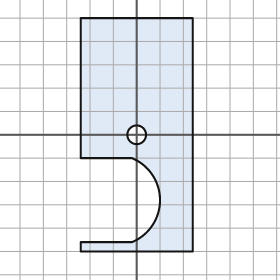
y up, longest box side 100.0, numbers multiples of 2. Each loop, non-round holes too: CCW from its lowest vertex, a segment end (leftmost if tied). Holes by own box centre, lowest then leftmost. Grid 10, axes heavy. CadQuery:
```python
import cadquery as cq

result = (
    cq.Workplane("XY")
    .moveTo(-24.0, -50.0)
    .lineTo(24.0, -50.0)
    .lineTo(24.0, 50.0)
    .lineTo(-24.0, 50.0)
    .lineTo(-24.0, -10.0)
    .lineTo(-2.0, -10.0)
    .threePointArc((10.0, -28.0), (-2.0, -46.0))
    .lineTo(-24.0, -46.0)
    .close()
    .moveTo(0.0, 0.0)
    .circle(4.0)
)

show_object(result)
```